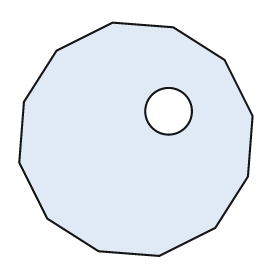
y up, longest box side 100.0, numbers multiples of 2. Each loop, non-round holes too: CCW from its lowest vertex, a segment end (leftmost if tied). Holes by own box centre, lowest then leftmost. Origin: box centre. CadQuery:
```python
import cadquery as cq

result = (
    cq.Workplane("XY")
    .moveTo(10.0, -50.0)
    .lineTo(34.0, -38.0)
    .lineTo(48.0, -16.0)
    .lineTo(50.0, 10.0)
    .lineTo(38.0, 34.0)
    .lineTo(16.0, 48.0)
    .lineTo(-10.0, 50.0)
    .lineTo(-34.0, 38.0)
    .lineTo(-48.0, 16.0)
    .lineTo(-50.0, -10.0)
    .lineTo(-38.0, -34.0)
    .lineTo(-16.0, -48.0)
    .close()
    .moveTo(14.0, 12.0)
    .circle(10.0)
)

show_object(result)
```